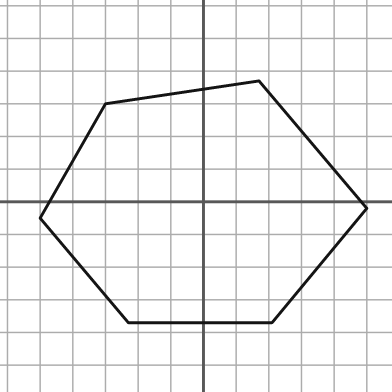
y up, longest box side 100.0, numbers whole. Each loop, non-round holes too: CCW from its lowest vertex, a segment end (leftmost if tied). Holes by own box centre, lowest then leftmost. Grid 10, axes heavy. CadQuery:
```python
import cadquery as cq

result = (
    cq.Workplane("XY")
    .moveTo(-23.0, -37.0)
    .lineTo(21.0, -37.0)
    .lineTo(50.0, -2.0)
    .lineTo(17.0, 37.0)
    .lineTo(-30.0, 30.0)
    .lineTo(-50.0, -5.0)
    .close()
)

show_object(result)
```